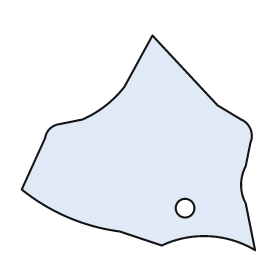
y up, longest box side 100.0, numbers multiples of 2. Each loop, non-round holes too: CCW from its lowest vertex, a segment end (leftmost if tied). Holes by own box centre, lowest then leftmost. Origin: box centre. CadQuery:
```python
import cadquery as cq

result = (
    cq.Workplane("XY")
    .moveTo(50.0, -46.0)
    .lineTo(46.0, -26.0)
    .threePointArc((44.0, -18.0), (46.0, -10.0))
    .lineTo(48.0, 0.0)
    .threePointArc((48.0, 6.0), (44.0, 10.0))
    .lineTo(34.0, 16.0)
    .lineTo(6.0, 46.0)
    .lineTo(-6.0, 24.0)
    .threePointArc((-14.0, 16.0), (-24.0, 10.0))
    .lineTo(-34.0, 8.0)
    .threePointArc((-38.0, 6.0), (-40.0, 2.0))
    .lineTo(-50.0, -20.0)
    .threePointArc((-30.0, -32.0), (-8.0, -38.0))
    .lineTo(10.0, -44.0)
    .threePointArc((30.0, -40.0), (50.0, -46.0))
    .close()
    .moveTo(20.0, -28.0)
    .circle(4.0)
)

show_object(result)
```